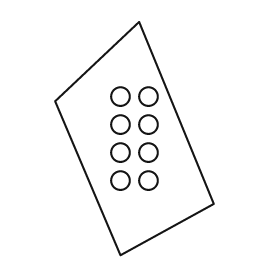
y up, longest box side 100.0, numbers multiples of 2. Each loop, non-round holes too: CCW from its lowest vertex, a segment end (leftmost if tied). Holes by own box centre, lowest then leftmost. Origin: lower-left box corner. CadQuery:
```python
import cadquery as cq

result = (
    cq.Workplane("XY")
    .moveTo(28.0, 0.0)
    .lineTo(68.0, 22.0)
    .lineTo(36.0, 100.0)
    .lineTo(0.0, 66.0)
    .close()
    .moveTo(28.0, 32.0)
    .circle(4.0)
    .moveTo(40.0, 32.0)
    .circle(4.0)
    .moveTo(28.0, 44.0)
    .circle(4.0)
    .moveTo(40.0, 44.0)
    .circle(4.0)
    .moveTo(28.0, 56.0)
    .circle(4.0)
    .moveTo(40.0, 56.0)
    .circle(4.0)
    .moveTo(28.0, 68.0)
    .circle(4.0)
    .moveTo(40.0, 68.0)
    .circle(4.0)
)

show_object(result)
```